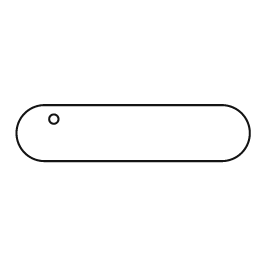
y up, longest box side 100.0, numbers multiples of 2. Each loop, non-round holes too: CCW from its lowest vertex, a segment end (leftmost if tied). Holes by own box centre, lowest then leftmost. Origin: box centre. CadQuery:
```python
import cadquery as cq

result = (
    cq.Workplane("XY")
    .moveTo(-38.0, -12.0)
    .lineTo(38.0, -12.0)
    .threePointArc((50.0, 0.0), (38.0, 12.0))
    .lineTo(-38.0, 12.0)
    .threePointArc((-50.0, 0.0), (-38.0, -12.0))
    .close()
    .moveTo(-34.0, 6.0)
    .circle(2.0)
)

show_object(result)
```